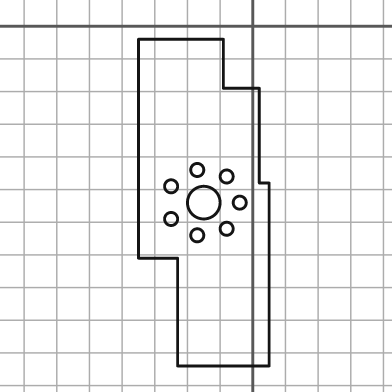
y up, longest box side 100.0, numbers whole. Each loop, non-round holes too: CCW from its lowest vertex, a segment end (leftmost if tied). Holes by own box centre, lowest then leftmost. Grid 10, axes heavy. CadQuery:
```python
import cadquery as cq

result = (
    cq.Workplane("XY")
    .moveTo(-23.0, -104.0)
    .lineTo(5.0, -104.0)
    .lineTo(5.0, -48.0)
    .lineTo(2.0, -48.0)
    .lineTo(2.0, -19.0)
    .lineTo(-9.0, -19.0)
    .lineTo(-9.0, -4.0)
    .lineTo(-35.0, -4.0)
    .lineTo(-35.0, -71.0)
    .lineTo(-23.0, -71.0)
    .close()
    .moveTo(-17.0, -64.0)
    .circle(2.0)
    .moveTo(-8.0, -62.0)
    .circle(2.0)
    .moveTo(-25.0, -59.0)
    .circle(2.0)
    .moveTo(-15.0, -54.0)
    .circle(5.0)
    .moveTo(-4.0, -54.0)
    .circle(2.0)
    .moveTo(-25.0, -49.0)
    .circle(2.0)
    .moveTo(-8.0, -46.0)
    .circle(2.0)
    .moveTo(-17.0, -44.0)
    .circle(2.0)
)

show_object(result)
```